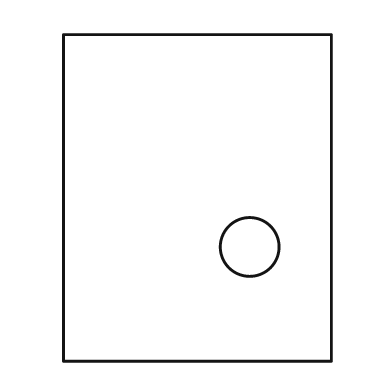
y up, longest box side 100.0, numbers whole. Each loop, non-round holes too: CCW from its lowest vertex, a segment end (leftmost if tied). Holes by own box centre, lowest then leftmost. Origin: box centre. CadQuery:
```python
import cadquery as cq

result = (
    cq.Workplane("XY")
    .moveTo(-41.0, -50.0)
    .lineTo(41.0, -50.0)
    .lineTo(41.0, 50.0)
    .lineTo(-41.0, 50.0)
    .close()
    .moveTo(16.0, -15.0)
    .circle(9.0)
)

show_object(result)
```